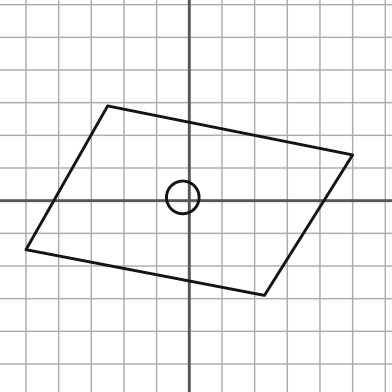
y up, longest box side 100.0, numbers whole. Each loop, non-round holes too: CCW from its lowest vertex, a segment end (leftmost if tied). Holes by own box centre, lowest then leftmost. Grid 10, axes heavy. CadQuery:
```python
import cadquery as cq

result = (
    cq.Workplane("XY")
    .moveTo(23.0, -29.0)
    .lineTo(50.0, 14.0)
    .lineTo(-25.0, 29.0)
    .lineTo(-50.0, -15.0)
    .close()
    .moveTo(-2.0, 1.0)
    .circle(5.0)
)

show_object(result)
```